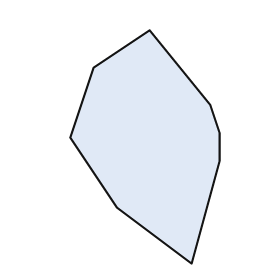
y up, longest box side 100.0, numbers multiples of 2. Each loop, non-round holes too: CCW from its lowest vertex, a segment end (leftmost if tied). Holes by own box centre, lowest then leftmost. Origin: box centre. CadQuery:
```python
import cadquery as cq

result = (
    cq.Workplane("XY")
    .moveTo(20.0, -50.0)
    .lineTo(32.0, -6.0)
    .lineTo(32.0, 6.0)
    .lineTo(28.0, 18.0)
    .lineTo(2.0, 50.0)
    .lineTo(-22.0, 34.0)
    .lineTo(-32.0, 4.0)
    .lineTo(-12.0, -26.0)
    .close()
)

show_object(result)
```